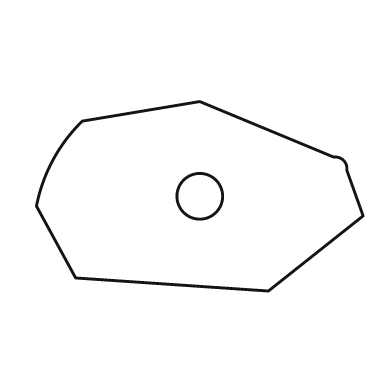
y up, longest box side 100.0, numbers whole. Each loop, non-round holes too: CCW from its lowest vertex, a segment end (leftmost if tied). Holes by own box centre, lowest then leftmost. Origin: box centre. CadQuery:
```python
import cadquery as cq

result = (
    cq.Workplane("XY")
    .moveTo(21.0, -29.0)
    .lineTo(50.0, -6.0)
    .lineTo(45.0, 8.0)
    .threePointArc((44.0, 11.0), (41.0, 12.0))
    .lineTo(0.0, 29.0)
    .lineTo(-36.0, 23.0)
    .threePointArc((-45.0, 11.0), (-50.0, -3.0))
    .lineTo(-38.0, -25.0)
    .close()
    .moveTo(0.0, 0.0)
    .circle(7.0)
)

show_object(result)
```